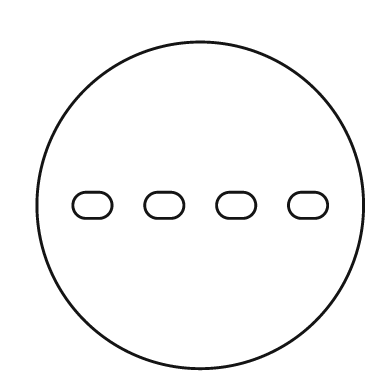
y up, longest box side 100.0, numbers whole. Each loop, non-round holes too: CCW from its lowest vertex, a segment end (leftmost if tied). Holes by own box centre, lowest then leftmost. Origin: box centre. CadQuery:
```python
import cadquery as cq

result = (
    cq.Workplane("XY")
    .moveTo(0.0, 0.0)
    .circle(50.0)
    .moveTo(-35.0, -4.0)
    .lineTo(-31.0, -4.0)
    .threePointArc((-27.0, 0.0), (-31.0, 4.0))
    .lineTo(-35.0, 4.0)
    .threePointArc((-39.0, 0.0), (-35.0, -4.0))
    .close()
    .moveTo(-13.0, -4.0)
    .lineTo(-9.0, -4.0)
    .threePointArc((-5.0, 0.0), (-9.0, 4.0))
    .lineTo(-13.0, 4.0)
    .threePointArc((-17.0, 0.0), (-13.0, -4.0))
    .close()
    .moveTo(9.0, -4.0)
    .lineTo(13.0, -4.0)
    .threePointArc((17.0, 0.0), (13.0, 4.0))
    .lineTo(9.0, 4.0)
    .threePointArc((5.0, 0.0), (9.0, -4.0))
    .close()
    .moveTo(31.0, -4.0)
    .lineTo(35.0, -4.0)
    .threePointArc((39.0, 0.0), (35.0, 4.0))
    .lineTo(31.0, 4.0)
    .threePointArc((27.0, 0.0), (31.0, -4.0))
    .close()
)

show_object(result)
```